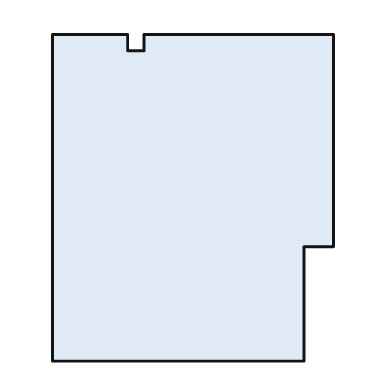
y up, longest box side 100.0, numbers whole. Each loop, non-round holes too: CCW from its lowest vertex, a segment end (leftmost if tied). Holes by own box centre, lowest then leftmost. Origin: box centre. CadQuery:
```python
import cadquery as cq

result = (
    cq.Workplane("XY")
    .moveTo(-43.0, -50.0)
    .lineTo(34.0, -50.0)
    .lineTo(34.0, -15.0)
    .lineTo(43.0, -15.0)
    .lineTo(43.0, 50.0)
    .lineTo(-15.0, 50.0)
    .lineTo(-15.0, 45.0)
    .lineTo(-20.0, 45.0)
    .lineTo(-20.0, 50.0)
    .lineTo(-43.0, 50.0)
    .close()
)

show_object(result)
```